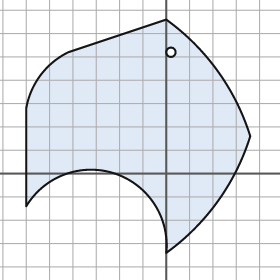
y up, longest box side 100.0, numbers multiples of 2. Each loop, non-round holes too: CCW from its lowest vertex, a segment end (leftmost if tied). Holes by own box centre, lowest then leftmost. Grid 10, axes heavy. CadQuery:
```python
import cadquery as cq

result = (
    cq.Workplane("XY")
    .moveTo(0.0, -34.0)
    .threePointArc((22.0, -12.0), (36.0, 16.0))
    .threePointArc((22.0, 44.0), (0.0, 66.0))
    .lineTo(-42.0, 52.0)
    .threePointArc((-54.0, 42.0), (-60.0, 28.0))
    .lineTo(-60.0, -14.0)
    .threePointArc((-22.0, 0.0), (0.0, -34.0))
    .close()
    .moveTo(2.0, 52.0)
    .circle(2.0)
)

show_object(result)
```